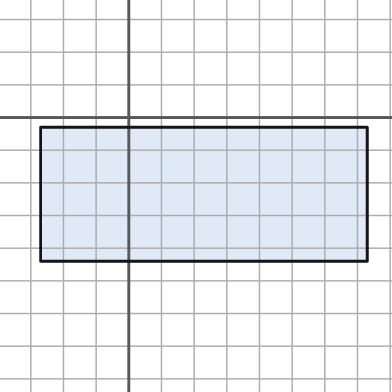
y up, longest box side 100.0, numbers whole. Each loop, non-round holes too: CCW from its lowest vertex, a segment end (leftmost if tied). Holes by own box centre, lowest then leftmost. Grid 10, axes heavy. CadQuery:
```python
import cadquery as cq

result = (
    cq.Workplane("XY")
    .moveTo(-27.0, -44.0)
    .lineTo(73.0, -44.0)
    .lineTo(73.0, -3.0)
    .lineTo(-27.0, -3.0)
    .close()
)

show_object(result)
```